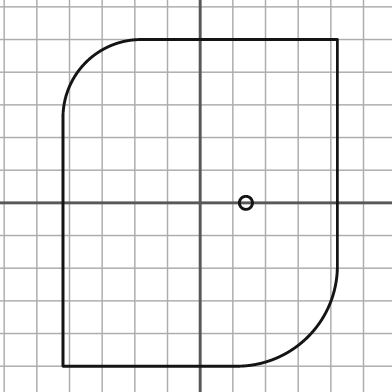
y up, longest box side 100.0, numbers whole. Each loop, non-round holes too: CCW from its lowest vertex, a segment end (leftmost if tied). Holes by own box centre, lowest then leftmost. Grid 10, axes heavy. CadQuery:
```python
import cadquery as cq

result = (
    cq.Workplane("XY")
    .moveTo(-42.0, -50.0)
    .lineTo(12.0, -50.0)
    .threePointArc((33.0, -41.0), (42.0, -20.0))
    .lineTo(42.0, 50.0)
    .lineTo(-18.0, 50.0)
    .threePointArc((-35.0, 43.0), (-42.0, 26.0))
    .close()
    .moveTo(14.0, 0.0)
    .circle(2.0)
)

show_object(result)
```